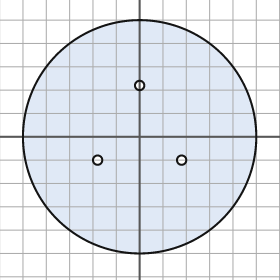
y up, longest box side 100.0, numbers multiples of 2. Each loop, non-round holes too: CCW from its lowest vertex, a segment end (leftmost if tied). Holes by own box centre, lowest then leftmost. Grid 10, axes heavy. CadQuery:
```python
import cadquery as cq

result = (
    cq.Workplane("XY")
    .moveTo(0.0, 0.0)
    .circle(50.0)
    .moveTo(-18.0, -10.0)
    .circle(2.0)
    .moveTo(18.0, -10.0)
    .circle(2.0)
    .moveTo(0.0, 22.0)
    .circle(2.0)
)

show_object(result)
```